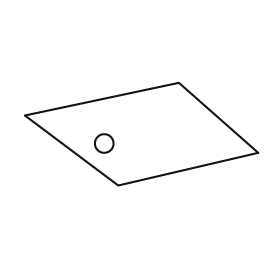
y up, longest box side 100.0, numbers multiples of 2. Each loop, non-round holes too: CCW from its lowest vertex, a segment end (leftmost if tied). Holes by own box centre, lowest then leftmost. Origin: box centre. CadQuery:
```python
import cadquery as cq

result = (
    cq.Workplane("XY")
    .moveTo(-10.0, -22.0)
    .lineTo(50.0, -8.0)
    .lineTo(16.0, 22.0)
    .lineTo(-50.0, 8.0)
    .close()
    .moveTo(-16.0, -4.0)
    .circle(4.0)
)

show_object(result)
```